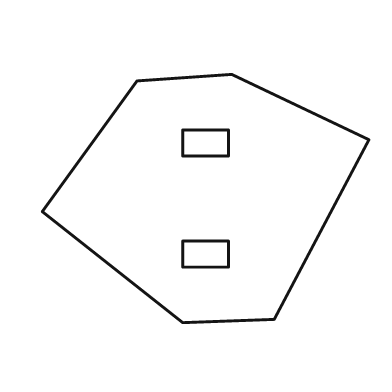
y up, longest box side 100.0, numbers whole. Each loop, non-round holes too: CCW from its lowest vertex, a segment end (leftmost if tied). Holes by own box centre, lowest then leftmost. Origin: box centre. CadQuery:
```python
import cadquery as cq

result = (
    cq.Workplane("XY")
    .moveTo(-7.0, -38.0)
    .lineTo(21.0, -37.0)
    .lineTo(50.0, 18.0)
    .lineTo(8.0, 38.0)
    .lineTo(-21.0, 36.0)
    .lineTo(-50.0, -4.0)
    .close()
    .moveTo(-7.0, -21.0)
    .lineTo(7.0, -21.0)
    .lineTo(7.0, -13.0)
    .lineTo(-7.0, -13.0)
    .close()
    .moveTo(-7.0, 13.0)
    .lineTo(7.0, 13.0)
    .lineTo(7.0, 21.0)
    .lineTo(-7.0, 21.0)
    .close()
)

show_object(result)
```